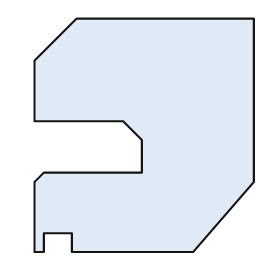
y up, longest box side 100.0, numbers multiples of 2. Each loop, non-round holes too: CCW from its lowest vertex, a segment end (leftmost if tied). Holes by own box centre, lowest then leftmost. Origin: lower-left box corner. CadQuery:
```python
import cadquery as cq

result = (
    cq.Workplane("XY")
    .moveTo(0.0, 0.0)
    .lineTo(4.0, 0.0)
    .lineTo(4.0, 8.0)
    .lineTo(16.0, 8.0)
    .lineTo(16.0, 0.0)
    .lineTo(68.0, 0.0)
    .lineTo(94.0, 30.0)
    .lineTo(94.0, 100.0)
    .lineTo(18.0, 100.0)
    .lineTo(0.0, 82.0)
    .lineTo(0.0, 56.0)
    .lineTo(38.0, 56.0)
    .lineTo(46.0, 48.0)
    .lineTo(46.0, 34.0)
    .lineTo(4.0, 34.0)
    .lineTo(0.0, 30.0)
    .close()
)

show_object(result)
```